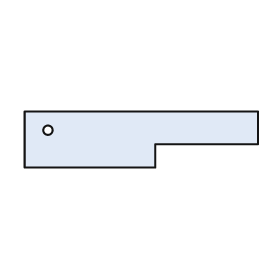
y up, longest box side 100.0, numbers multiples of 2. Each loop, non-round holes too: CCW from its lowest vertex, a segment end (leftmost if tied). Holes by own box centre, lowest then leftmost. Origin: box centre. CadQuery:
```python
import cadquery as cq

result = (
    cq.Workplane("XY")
    .moveTo(-50.0, -12.0)
    .lineTo(6.0, -12.0)
    .lineTo(6.0, -2.0)
    .lineTo(50.0, -2.0)
    .lineTo(50.0, 12.0)
    .lineTo(-50.0, 12.0)
    .close()
    .moveTo(-40.0, 4.0)
    .circle(2.0)
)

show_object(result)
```